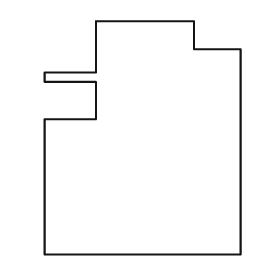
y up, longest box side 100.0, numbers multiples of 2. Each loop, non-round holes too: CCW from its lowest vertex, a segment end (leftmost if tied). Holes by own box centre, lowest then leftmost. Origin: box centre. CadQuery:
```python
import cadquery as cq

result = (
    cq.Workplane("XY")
    .moveTo(-42.0, -50.0)
    .lineTo(42.0, -50.0)
    .lineTo(42.0, 38.0)
    .lineTo(22.0, 38.0)
    .lineTo(22.0, 50.0)
    .lineTo(-20.0, 50.0)
    .lineTo(-20.0, 28.0)
    .lineTo(-42.0, 28.0)
    .lineTo(-42.0, 24.0)
    .lineTo(-20.0, 24.0)
    .lineTo(-20.0, 8.0)
    .lineTo(-42.0, 8.0)
    .close()
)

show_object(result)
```